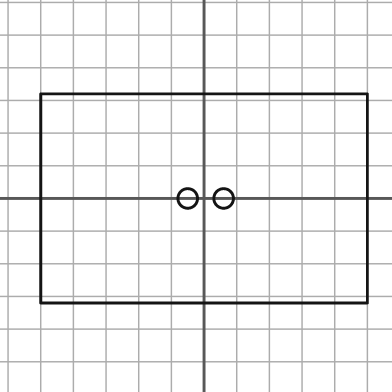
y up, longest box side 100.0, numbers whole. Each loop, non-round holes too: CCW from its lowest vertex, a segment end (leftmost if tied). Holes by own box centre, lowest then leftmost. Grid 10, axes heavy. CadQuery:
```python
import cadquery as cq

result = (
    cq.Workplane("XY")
    .moveTo(-50.0, -32.0)
    .lineTo(50.0, -32.0)
    .lineTo(50.0, 32.0)
    .lineTo(-50.0, 32.0)
    .close()
    .moveTo(-5.0, 0.0)
    .circle(3.0)
    .moveTo(6.0, 0.0)
    .circle(3.0)
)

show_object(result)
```